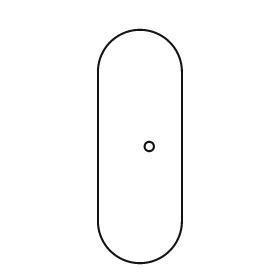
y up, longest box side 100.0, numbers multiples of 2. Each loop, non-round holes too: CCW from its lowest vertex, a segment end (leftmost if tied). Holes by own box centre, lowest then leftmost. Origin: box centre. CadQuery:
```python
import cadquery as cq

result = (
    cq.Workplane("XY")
    .moveTo(-18.0, -32.0)
    .threePointArc((0.0, -50.0), (18.0, -32.0))
    .lineTo(18.0, 32.0)
    .threePointArc((0.0, 50.0), (-18.0, 32.0))
    .close()
    .moveTo(4.0, 0.0)
    .circle(2.0)
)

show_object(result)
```